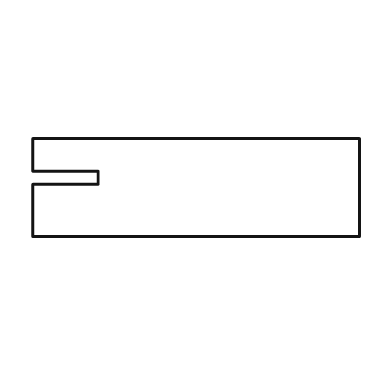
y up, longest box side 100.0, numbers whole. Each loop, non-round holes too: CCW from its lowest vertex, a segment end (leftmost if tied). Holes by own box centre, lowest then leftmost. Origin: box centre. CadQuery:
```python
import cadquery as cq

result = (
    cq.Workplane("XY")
    .moveTo(-50.0, -15.0)
    .lineTo(50.0, -15.0)
    .lineTo(50.0, 15.0)
    .lineTo(-50.0, 15.0)
    .lineTo(-50.0, 5.0)
    .lineTo(-30.0, 5.0)
    .lineTo(-30.0, 1.0)
    .lineTo(-50.0, 1.0)
    .close()
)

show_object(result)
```